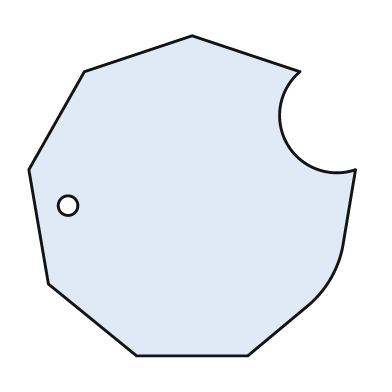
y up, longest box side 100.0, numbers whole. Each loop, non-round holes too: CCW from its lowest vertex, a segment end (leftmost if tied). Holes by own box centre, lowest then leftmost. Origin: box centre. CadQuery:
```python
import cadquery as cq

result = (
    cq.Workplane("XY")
    .moveTo(-17.0, -49.0)
    .lineTo(17.0, -49.0)
    .lineTo(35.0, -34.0)
    .threePointArc((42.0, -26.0), (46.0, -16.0))
    .lineTo(50.0, 8.0)
    .threePointArc((29.0, 16.0), (33.0, 38.0))
    .lineTo(0.0, 49.0)
    .lineTo(-33.0, 38.0)
    .lineTo(-50.0, 8.0)
    .lineTo(-44.0, -27.0)
    .close()
    .moveTo(-38.0, -3.0)
    .circle(3.0)
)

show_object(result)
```